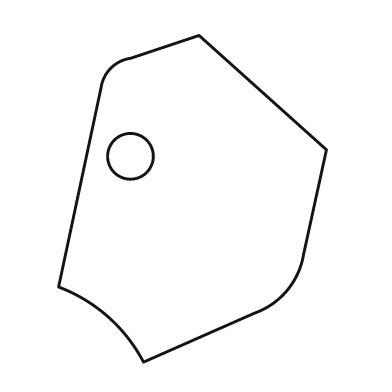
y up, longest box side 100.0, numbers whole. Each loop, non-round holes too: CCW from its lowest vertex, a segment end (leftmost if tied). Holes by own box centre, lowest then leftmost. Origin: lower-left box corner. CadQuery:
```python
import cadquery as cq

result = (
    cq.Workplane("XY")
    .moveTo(26.0, 0.0)
    .lineTo(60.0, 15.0)
    .threePointArc((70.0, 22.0), (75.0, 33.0))
    .lineTo(82.0, 65.0)
    .lineTo(43.0, 100.0)
    .lineTo(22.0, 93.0)
    .threePointArc((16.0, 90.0), (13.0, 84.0))
    .lineTo(0.0, 23.0)
    .threePointArc((15.0, 14.0), (26.0, 0.0))
    .close()
    .moveTo(22.0, 63.0)
    .circle(7.0)
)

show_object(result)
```